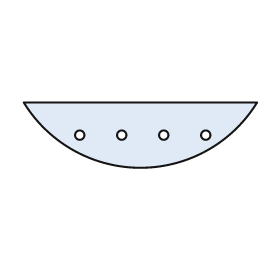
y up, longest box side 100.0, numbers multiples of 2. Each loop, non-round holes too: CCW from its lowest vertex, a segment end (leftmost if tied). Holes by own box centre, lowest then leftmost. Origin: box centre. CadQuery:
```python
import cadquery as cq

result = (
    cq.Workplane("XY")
    .moveTo(-50.0, 14.0)
    .threePointArc((0.0, -14.0), (50.0, 14.0))
    .close()
    .moveTo(-26.0, 0.0)
    .circle(2.0)
    .moveTo(-8.0, 0.0)
    .circle(2.0)
    .moveTo(10.0, 0.0)
    .circle(2.0)
    .moveTo(28.0, 0.0)
    .circle(2.0)
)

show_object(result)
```